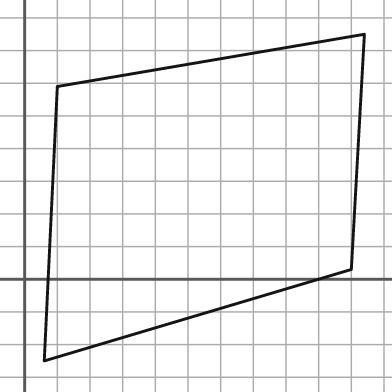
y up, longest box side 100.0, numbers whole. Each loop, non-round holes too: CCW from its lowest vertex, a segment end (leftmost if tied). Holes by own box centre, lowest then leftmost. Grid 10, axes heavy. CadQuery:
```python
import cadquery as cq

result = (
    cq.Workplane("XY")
    .moveTo(6.0, -25.0)
    .lineTo(100.0, 3.0)
    .lineTo(104.0, 75.0)
    .lineTo(10.0, 59.0)
    .close()
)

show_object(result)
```